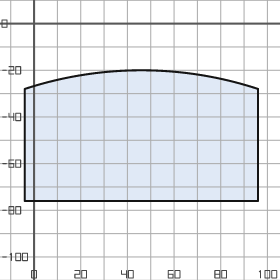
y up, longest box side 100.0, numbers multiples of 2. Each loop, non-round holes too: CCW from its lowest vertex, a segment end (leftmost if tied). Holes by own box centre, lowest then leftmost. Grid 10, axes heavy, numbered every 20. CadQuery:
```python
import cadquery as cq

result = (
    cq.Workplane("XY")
    .moveTo(-4.0, -76.0)
    .lineTo(96.0, -76.0)
    .lineTo(96.0, -28.0)
    .threePointArc((46.0, -20.0), (-4.0, -28.0))
    .close()
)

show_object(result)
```